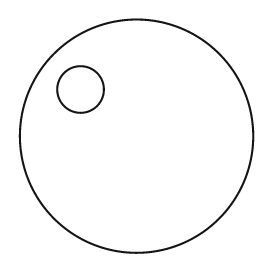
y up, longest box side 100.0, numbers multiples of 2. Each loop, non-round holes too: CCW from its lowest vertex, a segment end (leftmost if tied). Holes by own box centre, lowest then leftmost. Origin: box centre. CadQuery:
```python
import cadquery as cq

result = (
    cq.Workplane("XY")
    .moveTo(0.0, 0.0)
    .circle(50.0)
    .moveTo(-24.0, 20.0)
    .circle(10.0)
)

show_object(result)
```